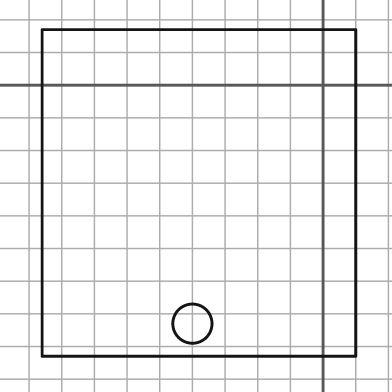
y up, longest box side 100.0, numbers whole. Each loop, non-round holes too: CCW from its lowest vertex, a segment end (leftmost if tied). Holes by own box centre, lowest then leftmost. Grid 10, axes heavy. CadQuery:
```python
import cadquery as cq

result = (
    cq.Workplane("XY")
    .moveTo(-86.0, -83.0)
    .lineTo(10.0, -83.0)
    .lineTo(10.0, 17.0)
    .lineTo(-86.0, 17.0)
    .close()
    .moveTo(-40.0, -73.0)
    .circle(6.0)
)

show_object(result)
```